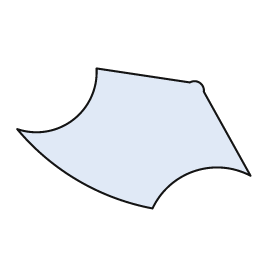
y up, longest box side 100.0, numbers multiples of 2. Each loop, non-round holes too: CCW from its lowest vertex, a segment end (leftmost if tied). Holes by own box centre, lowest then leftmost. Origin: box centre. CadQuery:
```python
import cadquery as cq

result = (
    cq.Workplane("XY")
    .moveTo(8.0, -30.0)
    .threePointArc((26.0, -14.0), (50.0, -16.0))
    .lineTo(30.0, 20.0)
    .threePointArc((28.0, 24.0), (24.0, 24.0))
    .lineTo(-16.0, 30.0)
    .threePointArc((-26.0, 8.0), (-50.0, 4.0))
    .threePointArc((-24.0, -18.0), (8.0, -30.0))
    .close()
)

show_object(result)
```